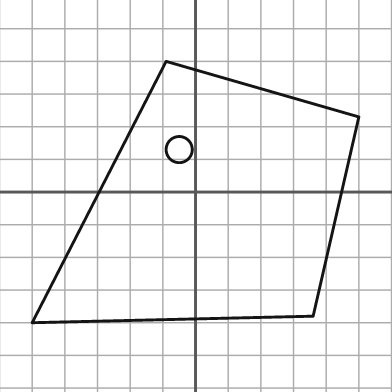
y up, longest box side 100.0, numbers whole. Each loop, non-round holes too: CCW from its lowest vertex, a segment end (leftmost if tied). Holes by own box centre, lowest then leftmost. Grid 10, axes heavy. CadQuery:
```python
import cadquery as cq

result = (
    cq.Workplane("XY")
    .moveTo(-50.0, -40.0)
    .lineTo(36.0, -38.0)
    .lineTo(50.0, 23.0)
    .lineTo(-9.0, 40.0)
    .close()
    .moveTo(-5.0, 13.0)
    .circle(4.0)
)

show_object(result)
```